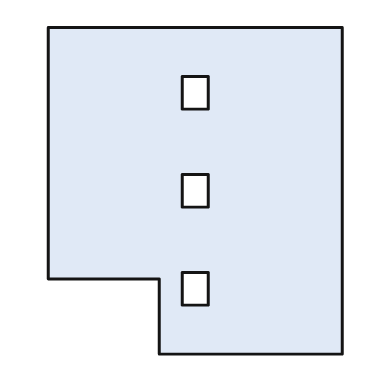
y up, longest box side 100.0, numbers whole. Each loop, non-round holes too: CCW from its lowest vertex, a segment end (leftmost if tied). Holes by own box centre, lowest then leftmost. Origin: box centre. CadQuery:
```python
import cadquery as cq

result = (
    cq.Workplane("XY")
    .moveTo(-11.0, -50.0)
    .lineTo(45.0, -50.0)
    .lineTo(45.0, 50.0)
    .lineTo(-45.0, 50.0)
    .lineTo(-45.0, -27.0)
    .lineTo(-11.0, -27.0)
    .close()
    .moveTo(-4.0, -35.0)
    .lineTo(4.0, -35.0)
    .lineTo(4.0, -25.0)
    .lineTo(-4.0, -25.0)
    .close()
    .moveTo(-4.0, -5.0)
    .lineTo(4.0, -5.0)
    .lineTo(4.0, 5.0)
    .lineTo(-4.0, 5.0)
    .close()
    .moveTo(-4.0, 25.0)
    .lineTo(4.0, 25.0)
    .lineTo(4.0, 35.0)
    .lineTo(-4.0, 35.0)
    .close()
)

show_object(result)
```